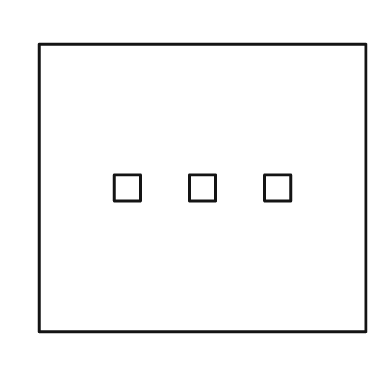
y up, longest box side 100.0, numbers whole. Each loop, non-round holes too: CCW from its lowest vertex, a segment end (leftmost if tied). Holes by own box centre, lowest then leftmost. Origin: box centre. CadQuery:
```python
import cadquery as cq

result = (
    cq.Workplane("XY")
    .moveTo(-50.0, -44.0)
    .lineTo(50.0, -44.0)
    .lineTo(50.0, 44.0)
    .lineTo(-50.0, 44.0)
    .close()
    .moveTo(-27.0, -4.0)
    .lineTo(-19.0, -4.0)
    .lineTo(-19.0, 4.0)
    .lineTo(-27.0, 4.0)
    .close()
    .moveTo(-4.0, -4.0)
    .lineTo(4.0, -4.0)
    .lineTo(4.0, 4.0)
    .lineTo(-4.0, 4.0)
    .close()
    .moveTo(19.0, -4.0)
    .lineTo(27.0, -4.0)
    .lineTo(27.0, 4.0)
    .lineTo(19.0, 4.0)
    .close()
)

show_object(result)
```